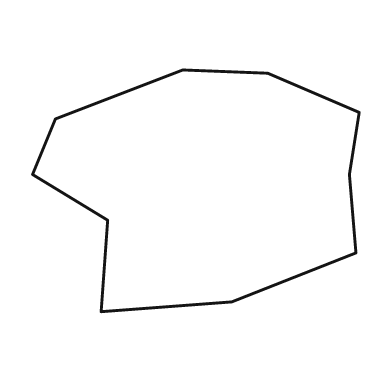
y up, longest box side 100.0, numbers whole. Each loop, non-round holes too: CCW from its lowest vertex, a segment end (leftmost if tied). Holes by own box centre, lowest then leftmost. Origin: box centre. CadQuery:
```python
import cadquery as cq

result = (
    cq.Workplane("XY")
    .moveTo(-29.0, -37.0)
    .lineTo(11.0, -34.0)
    .lineTo(49.0, -19.0)
    .lineTo(47.0, 5.0)
    .lineTo(50.0, 24.0)
    .lineTo(22.0, 36.0)
    .lineTo(-4.0, 37.0)
    .lineTo(-43.0, 22.0)
    .lineTo(-50.0, 5.0)
    .lineTo(-27.0, -9.0)
    .close()
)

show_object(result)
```